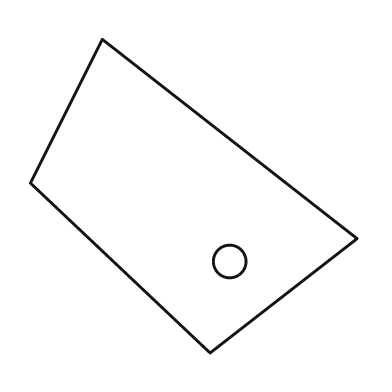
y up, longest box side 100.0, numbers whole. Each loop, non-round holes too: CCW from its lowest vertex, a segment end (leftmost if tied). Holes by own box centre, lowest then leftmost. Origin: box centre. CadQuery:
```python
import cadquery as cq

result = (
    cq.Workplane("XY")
    .moveTo(5.0, -48.0)
    .lineTo(50.0, -13.0)
    .lineTo(-28.0, 48.0)
    .lineTo(-50.0, 4.0)
    .close()
    .moveTo(11.0, -20.0)
    .circle(5.0)
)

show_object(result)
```